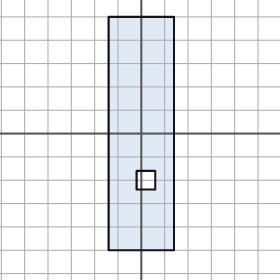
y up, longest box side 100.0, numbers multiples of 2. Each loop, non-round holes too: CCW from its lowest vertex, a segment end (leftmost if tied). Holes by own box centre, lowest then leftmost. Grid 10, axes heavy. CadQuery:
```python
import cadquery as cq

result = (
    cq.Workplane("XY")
    .moveTo(-14.0, -50.0)
    .lineTo(14.0, -50.0)
    .lineTo(14.0, 50.0)
    .lineTo(-14.0, 50.0)
    .close()
    .moveTo(-2.0, -24.0)
    .lineTo(6.0, -24.0)
    .lineTo(6.0, -16.0)
    .lineTo(-2.0, -16.0)
    .close()
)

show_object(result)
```